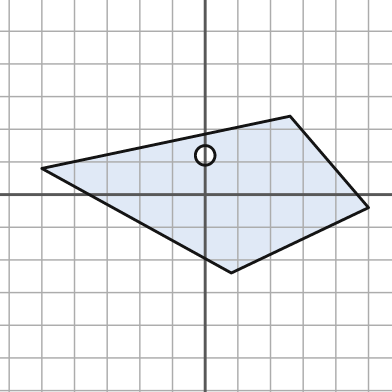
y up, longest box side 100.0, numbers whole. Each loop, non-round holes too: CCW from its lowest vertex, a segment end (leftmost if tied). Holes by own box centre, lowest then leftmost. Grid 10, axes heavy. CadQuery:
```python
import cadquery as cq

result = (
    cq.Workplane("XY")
    .moveTo(8.0, -24.0)
    .lineTo(50.0, -4.0)
    .lineTo(26.0, 24.0)
    .lineTo(-50.0, 8.0)
    .close()
    .moveTo(0.0, 12.0)
    .circle(3.0)
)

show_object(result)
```